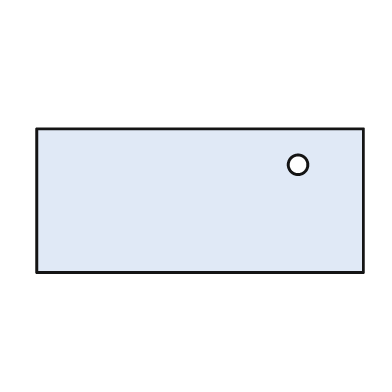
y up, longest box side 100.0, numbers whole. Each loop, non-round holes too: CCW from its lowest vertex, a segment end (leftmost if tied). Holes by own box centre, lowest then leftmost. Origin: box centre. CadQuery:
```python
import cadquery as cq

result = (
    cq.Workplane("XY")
    .moveTo(-50.0, -22.0)
    .lineTo(50.0, -22.0)
    .lineTo(50.0, 22.0)
    .lineTo(-50.0, 22.0)
    .close()
    .moveTo(30.0, 11.0)
    .circle(3.0)
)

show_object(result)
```